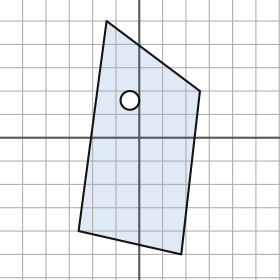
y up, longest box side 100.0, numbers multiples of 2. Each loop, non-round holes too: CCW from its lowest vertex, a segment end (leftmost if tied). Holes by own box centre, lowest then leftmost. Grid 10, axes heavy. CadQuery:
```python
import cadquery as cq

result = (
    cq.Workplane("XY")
    .moveTo(18.0, -50.0)
    .lineTo(26.0, 20.0)
    .lineTo(-14.0, 50.0)
    .lineTo(-26.0, -40.0)
    .close()
    .moveTo(-4.0, 16.0)
    .circle(4.0)
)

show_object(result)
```